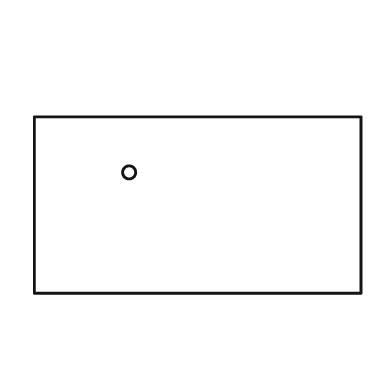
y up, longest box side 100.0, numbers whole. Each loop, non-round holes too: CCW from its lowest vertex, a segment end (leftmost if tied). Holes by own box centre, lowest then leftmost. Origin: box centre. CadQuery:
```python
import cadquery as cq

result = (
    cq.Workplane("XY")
    .moveTo(-50.0, -27.0)
    .lineTo(50.0, -27.0)
    .lineTo(50.0, 27.0)
    .lineTo(-50.0, 27.0)
    .close()
    .moveTo(-21.0, 10.0)
    .circle(2.0)
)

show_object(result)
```